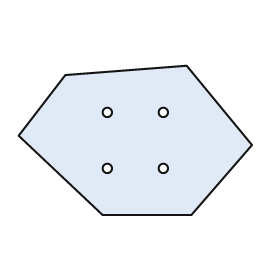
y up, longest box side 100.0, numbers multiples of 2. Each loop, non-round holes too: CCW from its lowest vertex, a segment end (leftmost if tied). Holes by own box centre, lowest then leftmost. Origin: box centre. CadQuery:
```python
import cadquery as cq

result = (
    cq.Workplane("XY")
    .moveTo(-14.0, -32.0)
    .lineTo(24.0, -32.0)
    .lineTo(50.0, -2.0)
    .lineTo(22.0, 32.0)
    .lineTo(-30.0, 28.0)
    .lineTo(-50.0, 2.0)
    .close()
    .moveTo(-12.0, -12.0)
    .circle(2.0)
    .moveTo(12.0, -12.0)
    .circle(2.0)
    .moveTo(-12.0, 12.0)
    .circle(2.0)
    .moveTo(12.0, 12.0)
    .circle(2.0)
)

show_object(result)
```